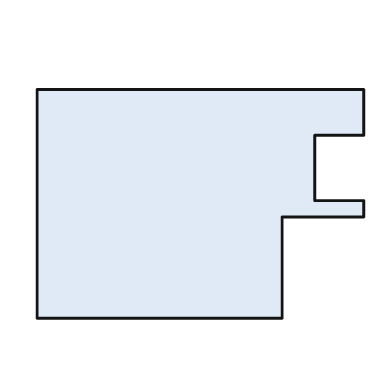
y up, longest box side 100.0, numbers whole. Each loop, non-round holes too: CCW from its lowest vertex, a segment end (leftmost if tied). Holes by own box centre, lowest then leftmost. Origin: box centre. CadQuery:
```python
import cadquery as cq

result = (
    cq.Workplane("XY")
    .moveTo(-50.0, -35.0)
    .lineTo(25.0, -35.0)
    .lineTo(25.0, -4.0)
    .lineTo(50.0, -4.0)
    .lineTo(50.0, 1.0)
    .lineTo(35.0, 1.0)
    .lineTo(35.0, 21.0)
    .lineTo(50.0, 21.0)
    .lineTo(50.0, 35.0)
    .lineTo(-50.0, 35.0)
    .close()
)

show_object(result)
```